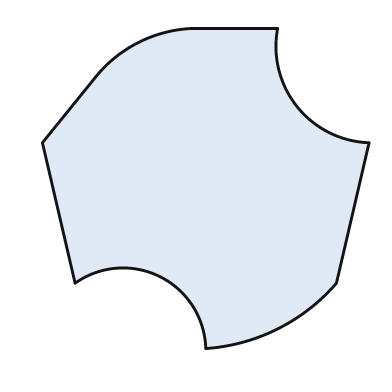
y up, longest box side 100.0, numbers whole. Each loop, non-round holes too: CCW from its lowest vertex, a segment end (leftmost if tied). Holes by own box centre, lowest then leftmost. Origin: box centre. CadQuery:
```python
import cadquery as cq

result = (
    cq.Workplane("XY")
    .moveTo(0.0, -49.0)
    .threePointArc((22.0, -43.0), (40.0, -29.0))
    .lineTo(50.0, 14.0)
    .threePointArc((28.0, 25.0), (22.0, 49.0))
    .lineTo(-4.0, 49.0)
    .threePointArc((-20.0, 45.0), (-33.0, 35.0))
    .lineTo(-50.0, 14.0)
    .lineTo(-40.0, -29.0)
    .threePointArc((-14.0, -27.0), (0.0, -49.0))
    .close()
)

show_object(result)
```